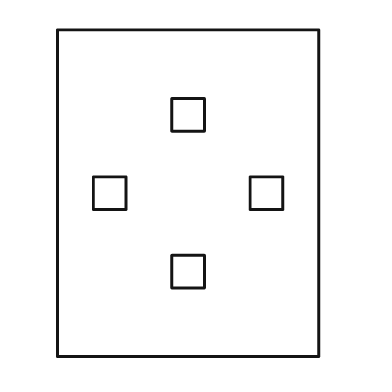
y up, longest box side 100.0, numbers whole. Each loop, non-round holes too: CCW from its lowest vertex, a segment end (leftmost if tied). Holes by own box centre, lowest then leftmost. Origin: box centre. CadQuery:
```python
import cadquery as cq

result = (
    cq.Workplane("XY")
    .moveTo(-40.0, -50.0)
    .lineTo(40.0, -50.0)
    .lineTo(40.0, 50.0)
    .lineTo(-40.0, 50.0)
    .close()
    .moveTo(-5.0, -29.0)
    .lineTo(5.0, -29.0)
    .lineTo(5.0, -19.0)
    .lineTo(-5.0, -19.0)
    .close()
    .moveTo(-29.0, -5.0)
    .lineTo(-19.0, -5.0)
    .lineTo(-19.0, 5.0)
    .lineTo(-29.0, 5.0)
    .close()
    .moveTo(19.0, -5.0)
    .lineTo(29.0, -5.0)
    .lineTo(29.0, 5.0)
    .lineTo(19.0, 5.0)
    .close()
    .moveTo(-5.0, 19.0)
    .lineTo(5.0, 19.0)
    .lineTo(5.0, 29.0)
    .lineTo(-5.0, 29.0)
    .close()
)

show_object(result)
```